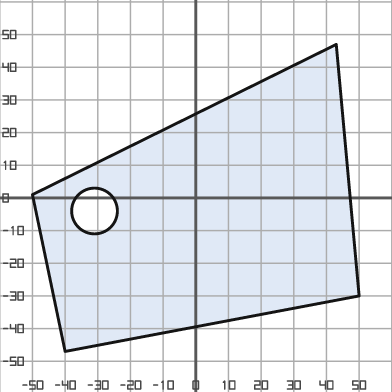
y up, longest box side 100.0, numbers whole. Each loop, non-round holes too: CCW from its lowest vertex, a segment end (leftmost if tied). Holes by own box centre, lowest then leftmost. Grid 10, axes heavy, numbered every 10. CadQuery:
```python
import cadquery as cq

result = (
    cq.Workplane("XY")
    .moveTo(-40.0, -47.0)
    .lineTo(50.0, -30.0)
    .lineTo(43.0, 47.0)
    .lineTo(-50.0, 1.0)
    .close()
    .moveTo(-31.0, -4.0)
    .circle(7.0)
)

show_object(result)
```